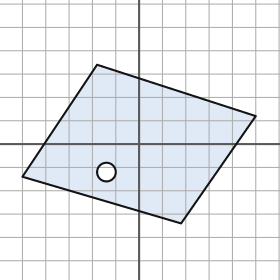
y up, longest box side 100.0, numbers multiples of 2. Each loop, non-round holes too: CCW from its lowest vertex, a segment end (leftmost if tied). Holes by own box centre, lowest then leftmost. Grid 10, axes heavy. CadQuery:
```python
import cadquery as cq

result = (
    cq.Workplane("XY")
    .moveTo(18.0, -34.0)
    .lineTo(50.0, 12.0)
    .lineTo(-18.0, 34.0)
    .lineTo(-50.0, -14.0)
    .close()
    .moveTo(-14.0, -12.0)
    .circle(4.0)
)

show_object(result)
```